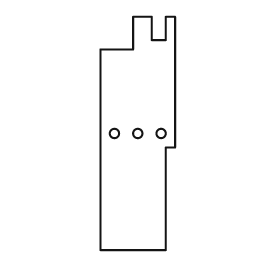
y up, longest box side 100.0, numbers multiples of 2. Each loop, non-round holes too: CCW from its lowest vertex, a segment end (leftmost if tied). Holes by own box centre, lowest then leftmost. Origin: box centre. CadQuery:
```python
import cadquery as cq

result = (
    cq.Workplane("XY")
    .moveTo(-16.0, -50.0)
    .lineTo(12.0, -50.0)
    .lineTo(12.0, -6.0)
    .lineTo(16.0, -6.0)
    .lineTo(16.0, 50.0)
    .lineTo(12.0, 50.0)
    .lineTo(12.0, 40.0)
    .lineTo(6.0, 40.0)
    .lineTo(6.0, 50.0)
    .lineTo(-2.0, 50.0)
    .lineTo(-2.0, 36.0)
    .lineTo(-16.0, 36.0)
    .close()
    .moveTo(-10.0, 0.0)
    .circle(2.0)
    .moveTo(0.0, 0.0)
    .circle(2.0)
    .moveTo(10.0, 0.0)
    .circle(2.0)
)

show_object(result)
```